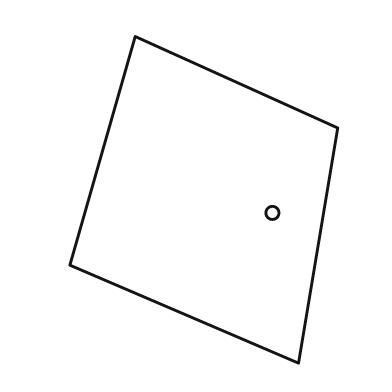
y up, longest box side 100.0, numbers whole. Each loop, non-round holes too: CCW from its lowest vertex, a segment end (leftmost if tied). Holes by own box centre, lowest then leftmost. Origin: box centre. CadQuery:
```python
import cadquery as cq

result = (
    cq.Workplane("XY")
    .moveTo(29.0, -50.0)
    .lineTo(41.0, 22.0)
    .lineTo(-21.0, 50.0)
    .lineTo(-41.0, -20.0)
    .close()
    .moveTo(21.0, -4.0)
    .circle(2.0)
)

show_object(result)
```